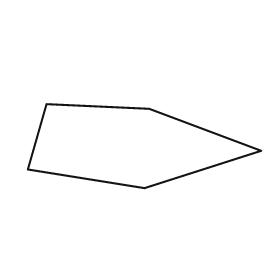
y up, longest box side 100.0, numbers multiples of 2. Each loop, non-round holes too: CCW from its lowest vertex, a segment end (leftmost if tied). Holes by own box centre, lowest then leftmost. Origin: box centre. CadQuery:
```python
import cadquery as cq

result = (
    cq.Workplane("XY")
    .moveTo(0.0, -18.0)
    .lineTo(50.0, -2.0)
    .lineTo(2.0, 16.0)
    .lineTo(-42.0, 18.0)
    .lineTo(-50.0, -10.0)
    .close()
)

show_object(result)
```